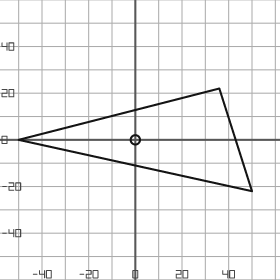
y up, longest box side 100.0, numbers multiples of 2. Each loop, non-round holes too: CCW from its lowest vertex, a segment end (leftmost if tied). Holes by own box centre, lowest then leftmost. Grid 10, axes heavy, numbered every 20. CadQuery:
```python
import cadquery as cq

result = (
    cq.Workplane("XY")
    .moveTo(50.0, -22.0)
    .lineTo(36.0, 22.0)
    .lineTo(-50.0, 0.0)
    .close()
    .moveTo(0.0, 0.0)
    .circle(2.0)
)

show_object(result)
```